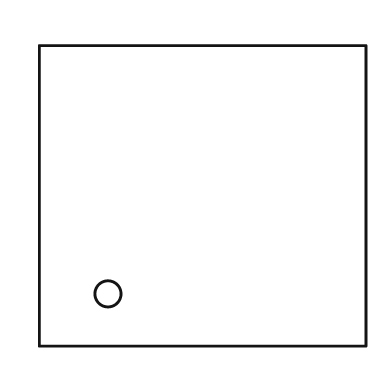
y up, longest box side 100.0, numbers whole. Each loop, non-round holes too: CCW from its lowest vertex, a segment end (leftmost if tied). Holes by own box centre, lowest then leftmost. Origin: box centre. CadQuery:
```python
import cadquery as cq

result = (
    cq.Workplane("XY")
    .moveTo(-50.0, -46.0)
    .lineTo(50.0, -46.0)
    .lineTo(50.0, 46.0)
    .lineTo(-50.0, 46.0)
    .close()
    .moveTo(-29.0, -30.0)
    .circle(4.0)
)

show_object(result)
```